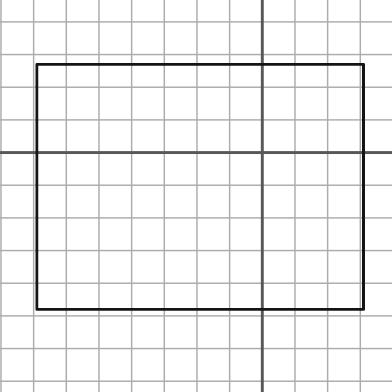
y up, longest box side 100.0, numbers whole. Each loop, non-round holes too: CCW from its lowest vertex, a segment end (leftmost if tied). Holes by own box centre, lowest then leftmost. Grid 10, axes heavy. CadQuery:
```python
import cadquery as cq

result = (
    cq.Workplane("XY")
    .moveTo(-69.0, -48.0)
    .lineTo(31.0, -48.0)
    .lineTo(31.0, 27.0)
    .lineTo(-69.0, 27.0)
    .close()
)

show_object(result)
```